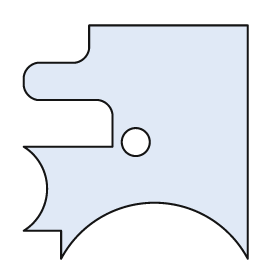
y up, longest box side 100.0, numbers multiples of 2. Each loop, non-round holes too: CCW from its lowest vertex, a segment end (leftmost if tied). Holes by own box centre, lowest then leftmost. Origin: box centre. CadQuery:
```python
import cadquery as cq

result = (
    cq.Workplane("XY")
    .moveTo(-32.0, -50.0)
    .threePointArc((8.0, -26.0), (48.0, -50.0))
    .lineTo(48.0, 50.0)
    .lineTo(-20.0, 50.0)
    .lineTo(-20.0, 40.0)
    .threePointArc((-22.0, 36.0), (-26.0, 34.0))
    .lineTo(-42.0, 34.0)
    .threePointArc((-46.0, 32.0), (-48.0, 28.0))
    .lineTo(-48.0, 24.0)
    .threePointArc((-46.0, 20.0), (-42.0, 18.0))
    .lineTo(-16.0, 18.0)
    .threePointArc((-12.0, 16.0), (-10.0, 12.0))
    .lineTo(-10.0, -2.0)
    .lineTo(-48.0, -2.0)
    .threePointArc((-38.0, -20.0), (-48.0, -38.0))
    .lineTo(-32.0, -38.0)
    .close()
    .moveTo(0.0, 0.0)
    .circle(6.0)
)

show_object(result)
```